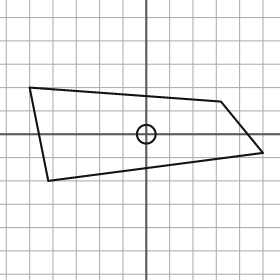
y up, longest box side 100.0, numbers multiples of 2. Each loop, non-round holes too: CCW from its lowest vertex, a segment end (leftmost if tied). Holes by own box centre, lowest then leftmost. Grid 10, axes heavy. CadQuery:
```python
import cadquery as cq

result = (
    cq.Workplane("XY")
    .moveTo(-42.0, -20.0)
    .lineTo(50.0, -8.0)
    .lineTo(32.0, 14.0)
    .lineTo(-50.0, 20.0)
    .close()
    .moveTo(0.0, 0.0)
    .circle(4.0)
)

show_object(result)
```